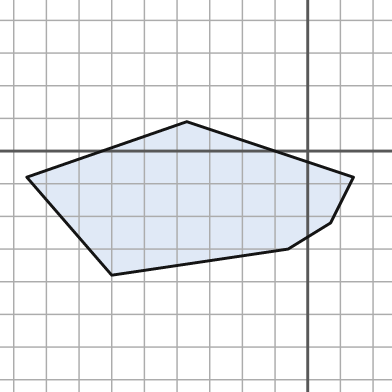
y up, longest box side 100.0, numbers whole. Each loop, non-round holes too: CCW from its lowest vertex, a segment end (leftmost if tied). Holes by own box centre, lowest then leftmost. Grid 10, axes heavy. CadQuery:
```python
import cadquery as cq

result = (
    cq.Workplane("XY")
    .moveTo(-60.0, -38.0)
    .lineTo(-6.0, -30.0)
    .lineTo(7.0, -22.0)
    .lineTo(14.0, -8.0)
    .lineTo(-37.0, 9.0)
    .lineTo(-86.0, -8.0)
    .close()
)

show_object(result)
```